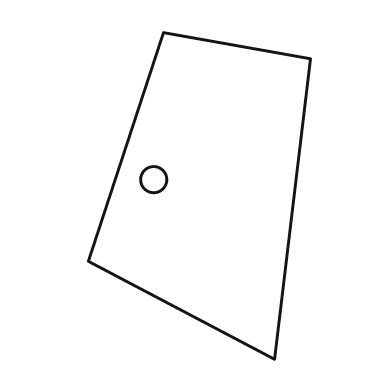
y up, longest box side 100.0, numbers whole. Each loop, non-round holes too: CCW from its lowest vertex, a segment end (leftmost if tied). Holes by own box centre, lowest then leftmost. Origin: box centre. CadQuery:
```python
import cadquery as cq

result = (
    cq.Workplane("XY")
    .moveTo(23.0, -50.0)
    .lineTo(34.0, 42.0)
    .lineTo(-11.0, 50.0)
    .lineTo(-34.0, -20.0)
    .close()
    .moveTo(-14.0, 5.0)
    .circle(4.0)
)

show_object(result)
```